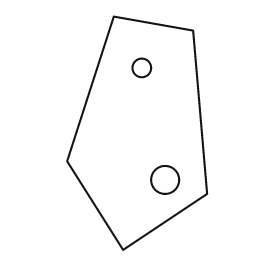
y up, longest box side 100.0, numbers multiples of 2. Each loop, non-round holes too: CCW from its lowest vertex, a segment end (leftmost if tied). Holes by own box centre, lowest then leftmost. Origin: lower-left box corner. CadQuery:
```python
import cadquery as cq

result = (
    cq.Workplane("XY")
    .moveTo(24.0, 0.0)
    .lineTo(60.0, 24.0)
    .lineTo(54.0, 94.0)
    .lineTo(20.0, 100.0)
    .lineTo(0.0, 38.0)
    .close()
    .moveTo(42.0, 30.0)
    .circle(6.0)
    .moveTo(32.0, 78.0)
    .circle(4.0)
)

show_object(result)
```